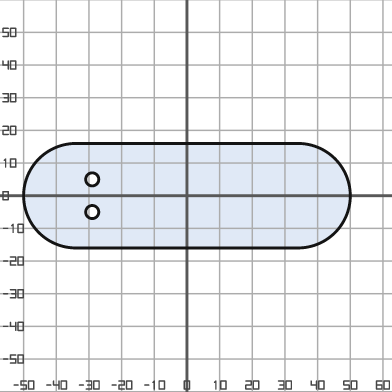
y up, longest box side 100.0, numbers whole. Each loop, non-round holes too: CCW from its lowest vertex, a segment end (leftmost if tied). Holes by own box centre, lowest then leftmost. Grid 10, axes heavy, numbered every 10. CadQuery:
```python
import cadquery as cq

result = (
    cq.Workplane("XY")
    .moveTo(-34.0, -16.0)
    .lineTo(34.0, -16.0)
    .threePointArc((50.0, 0.0), (34.0, 16.0))
    .lineTo(-34.0, 16.0)
    .threePointArc((-50.0, 0.0), (-34.0, -16.0))
    .close()
    .moveTo(-29.0, -5.0)
    .circle(2.0)
    .moveTo(-29.0, 5.0)
    .circle(2.0)
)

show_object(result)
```